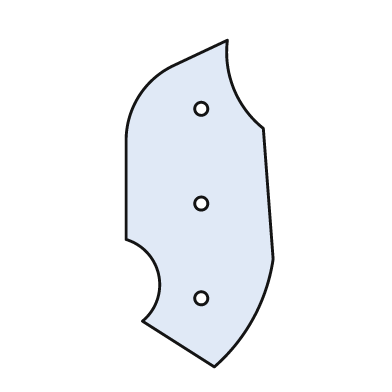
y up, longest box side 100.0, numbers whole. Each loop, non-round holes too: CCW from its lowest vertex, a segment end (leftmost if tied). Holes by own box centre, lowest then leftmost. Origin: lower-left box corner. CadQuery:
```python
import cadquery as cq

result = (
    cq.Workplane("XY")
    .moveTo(27.0, 0.0)
    .threePointArc((39.0, 15.0), (45.0, 33.0))
    .lineTo(42.0, 73.0)
    .threePointArc((33.0, 85.0), (31.0, 100.0))
    .lineTo(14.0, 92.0)
    .threePointArc((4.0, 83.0), (0.0, 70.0))
    .lineTo(0.0, 39.0)
    .threePointArc((10.0, 28.0), (5.0, 14.0))
    .close()
    .moveTo(23.0, 21.0)
    .circle(2.0)
    .moveTo(23.0, 50.0)
    .circle(2.0)
    .moveTo(23.0, 79.0)
    .circle(2.0)
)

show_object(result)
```